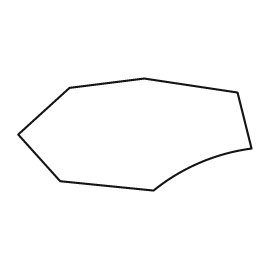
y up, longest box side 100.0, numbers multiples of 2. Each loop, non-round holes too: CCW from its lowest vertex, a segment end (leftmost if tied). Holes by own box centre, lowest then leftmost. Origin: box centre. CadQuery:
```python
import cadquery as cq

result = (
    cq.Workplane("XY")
    .moveTo(8.0, -24.0)
    .threePointArc((28.0, -12.0), (50.0, -6.0))
    .lineTo(44.0, 18.0)
    .lineTo(4.0, 24.0)
    .lineTo(-28.0, 20.0)
    .lineTo(-50.0, 0.0)
    .lineTo(-32.0, -20.0)
    .close()
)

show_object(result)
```